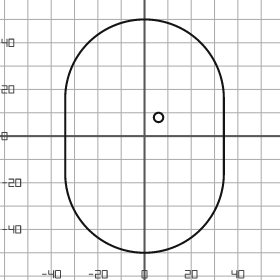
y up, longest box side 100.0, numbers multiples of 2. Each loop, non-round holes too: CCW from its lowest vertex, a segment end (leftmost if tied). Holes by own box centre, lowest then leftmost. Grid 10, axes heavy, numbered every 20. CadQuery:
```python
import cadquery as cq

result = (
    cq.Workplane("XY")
    .moveTo(-34.0, -16.0)
    .threePointArc((0.0, -50.0), (34.0, -16.0))
    .lineTo(34.0, 16.0)
    .threePointArc((0.0, 50.0), (-34.0, 16.0))
    .close()
    .moveTo(6.0, 8.0)
    .circle(2.0)
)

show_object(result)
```